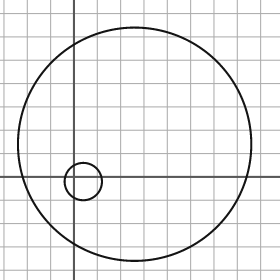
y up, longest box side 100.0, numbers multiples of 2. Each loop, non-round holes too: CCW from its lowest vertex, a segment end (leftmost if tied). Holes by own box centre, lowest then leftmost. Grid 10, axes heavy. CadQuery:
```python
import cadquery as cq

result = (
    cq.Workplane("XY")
    .moveTo(26.0, 14.0)
    .circle(50.0)
    .moveTo(4.0, -2.0)
    .circle(8.0)
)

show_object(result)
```